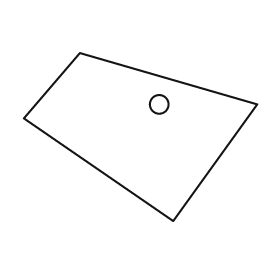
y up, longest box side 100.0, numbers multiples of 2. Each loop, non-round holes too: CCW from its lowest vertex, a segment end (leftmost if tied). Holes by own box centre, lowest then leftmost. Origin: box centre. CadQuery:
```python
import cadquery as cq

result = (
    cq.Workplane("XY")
    .moveTo(14.0, -36.0)
    .lineTo(50.0, 14.0)
    .lineTo(-26.0, 36.0)
    .lineTo(-50.0, 8.0)
    .close()
    .moveTo(8.0, 14.0)
    .circle(4.0)
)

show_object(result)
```